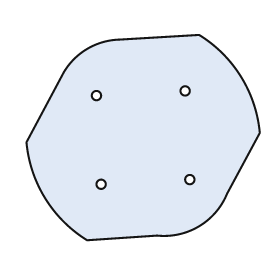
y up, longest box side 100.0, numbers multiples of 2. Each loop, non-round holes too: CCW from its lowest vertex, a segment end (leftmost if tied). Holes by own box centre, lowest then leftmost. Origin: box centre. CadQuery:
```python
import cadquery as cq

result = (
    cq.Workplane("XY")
    .moveTo(-24.0, -44.0)
    .lineTo(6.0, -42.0)
    .threePointArc((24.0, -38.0), (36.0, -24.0))
    .lineTo(50.0, 2.0)
    .threePointArc((42.0, 26.0), (24.0, 44.0))
    .lineTo(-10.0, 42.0)
    .threePointArc((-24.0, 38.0), (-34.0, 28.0))
    .lineTo(-50.0, -2.0)
    .threePointArc((-42.0, -26.0), (-24.0, -44.0))
    .close()
    .moveTo(-18.0, -20.0)
    .circle(2.0)
    .moveTo(20.0, -18.0)
    .circle(2.0)
    .moveTo(-20.0, 18.0)
    .circle(2.0)
    .moveTo(18.0, 20.0)
    .circle(2.0)
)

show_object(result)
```